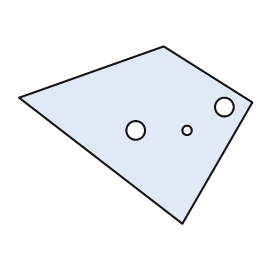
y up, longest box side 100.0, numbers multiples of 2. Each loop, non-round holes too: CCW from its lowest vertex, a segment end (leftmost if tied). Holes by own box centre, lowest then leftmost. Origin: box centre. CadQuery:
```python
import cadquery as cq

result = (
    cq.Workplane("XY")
    .moveTo(20.0, -38.0)
    .lineTo(50.0, 14.0)
    .lineTo(12.0, 38.0)
    .lineTo(-50.0, 16.0)
    .close()
    .moveTo(0.0, 2.0)
    .circle(4.0)
    .moveTo(22.0, 2.0)
    .circle(2.0)
    .moveTo(38.0, 12.0)
    .circle(4.0)
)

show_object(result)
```